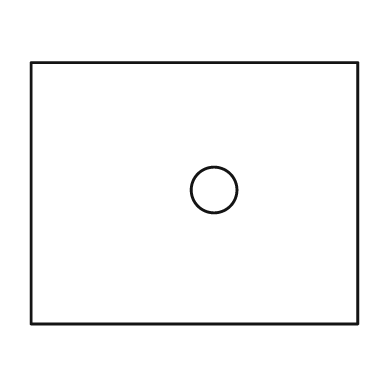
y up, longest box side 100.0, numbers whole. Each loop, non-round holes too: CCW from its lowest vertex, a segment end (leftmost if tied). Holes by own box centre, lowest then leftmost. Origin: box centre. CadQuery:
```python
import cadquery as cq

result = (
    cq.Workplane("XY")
    .moveTo(-50.0, -40.0)
    .lineTo(50.0, -40.0)
    .lineTo(50.0, 40.0)
    .lineTo(-50.0, 40.0)
    .close()
    .moveTo(6.0, 1.0)
    .circle(7.0)
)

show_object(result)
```